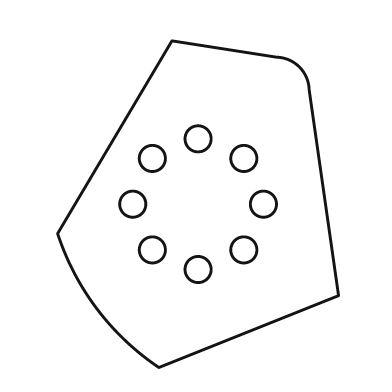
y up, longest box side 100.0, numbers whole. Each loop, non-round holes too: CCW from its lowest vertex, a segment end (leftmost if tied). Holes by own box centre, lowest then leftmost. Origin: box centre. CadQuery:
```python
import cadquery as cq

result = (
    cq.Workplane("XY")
    .moveTo(-12.0, -50.0)
    .lineTo(43.0, -28.0)
    .lineTo(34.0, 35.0)
    .threePointArc((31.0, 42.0), (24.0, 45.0))
    .lineTo(-8.0, 50.0)
    .lineTo(-43.0, -9.0)
    .threePointArc((-31.0, -32.0), (-12.0, -50.0))
    .close()
    .moveTo(0.0, -20.0)
    .circle(4.0)
    .moveTo(-14.0, -14.0)
    .circle(4.0)
    .moveTo(14.0, -14.0)
    .circle(4.0)
    .moveTo(-20.0, 0.0)
    .circle(4.0)
    .moveTo(20.0, 0.0)
    .circle(4.0)
    .moveTo(-14.0, 14.0)
    .circle(4.0)
    .moveTo(14.0, 14.0)
    .circle(4.0)
    .moveTo(0.0, 20.0)
    .circle(4.0)
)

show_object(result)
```